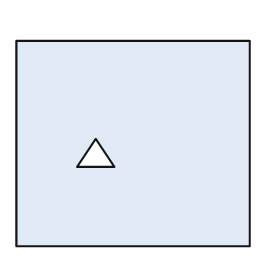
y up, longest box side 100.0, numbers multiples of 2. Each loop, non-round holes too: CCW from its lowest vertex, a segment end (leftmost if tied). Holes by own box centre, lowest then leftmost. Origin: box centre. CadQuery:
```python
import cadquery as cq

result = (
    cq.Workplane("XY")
    .moveTo(-50.0, -44.0)
    .lineTo(50.0, -44.0)
    .lineTo(50.0, 44.0)
    .lineTo(-50.0, 44.0)
    .close()
    .moveTo(-24.0, -10.0)
    .lineTo(-8.0, -10.0)
    .lineTo(-16.0, 2.0)
    .close()
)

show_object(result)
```